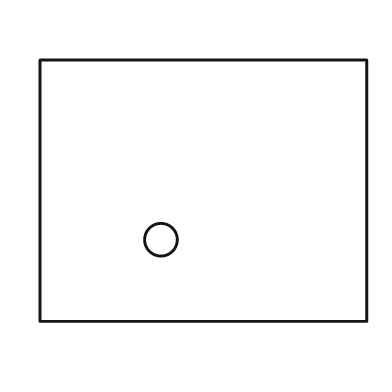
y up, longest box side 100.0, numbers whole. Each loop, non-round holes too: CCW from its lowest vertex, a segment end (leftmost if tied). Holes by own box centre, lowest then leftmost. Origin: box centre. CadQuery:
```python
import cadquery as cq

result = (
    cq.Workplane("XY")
    .moveTo(-50.0, -40.0)
    .lineTo(50.0, -40.0)
    .lineTo(50.0, 40.0)
    .lineTo(-50.0, 40.0)
    .close()
    .moveTo(-13.0, -15.0)
    .circle(5.0)
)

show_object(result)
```